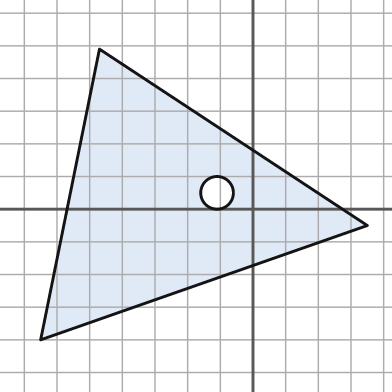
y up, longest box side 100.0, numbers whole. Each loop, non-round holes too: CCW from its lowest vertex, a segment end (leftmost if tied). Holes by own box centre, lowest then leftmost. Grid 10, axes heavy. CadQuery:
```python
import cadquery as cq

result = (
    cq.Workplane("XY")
    .moveTo(-65.0, -40.0)
    .lineTo(35.0, -5.0)
    .lineTo(-47.0, 49.0)
    .close()
    .moveTo(-11.0, 5.0)
    .circle(5.0)
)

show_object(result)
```